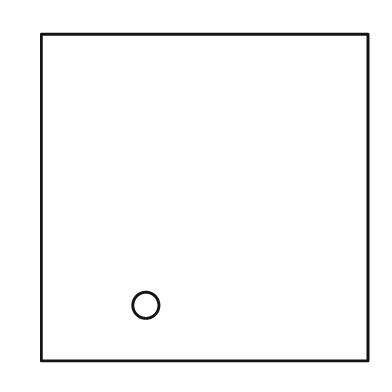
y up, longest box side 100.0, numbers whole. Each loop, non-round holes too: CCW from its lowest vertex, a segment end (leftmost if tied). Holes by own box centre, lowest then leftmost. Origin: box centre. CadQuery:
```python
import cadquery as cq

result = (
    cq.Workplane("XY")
    .moveTo(-50.0, -50.0)
    .lineTo(50.0, -50.0)
    .lineTo(50.0, 50.0)
    .lineTo(-50.0, 50.0)
    .close()
    .moveTo(-18.0, -33.0)
    .circle(4.0)
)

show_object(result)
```